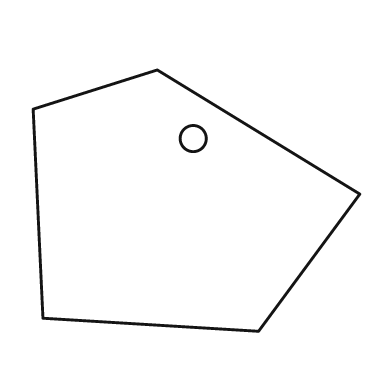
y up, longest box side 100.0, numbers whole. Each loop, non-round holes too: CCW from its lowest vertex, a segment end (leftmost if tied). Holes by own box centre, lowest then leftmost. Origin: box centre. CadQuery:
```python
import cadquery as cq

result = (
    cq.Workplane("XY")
    .moveTo(19.0, -40.0)
    .lineTo(50.0, 2.0)
    .lineTo(-12.0, 40.0)
    .lineTo(-50.0, 28.0)
    .lineTo(-47.0, -36.0)
    .close()
    .moveTo(-1.0, 19.0)
    .circle(4.0)
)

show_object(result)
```